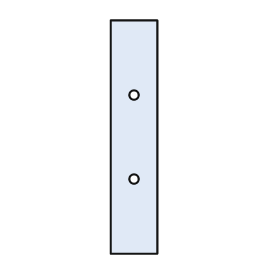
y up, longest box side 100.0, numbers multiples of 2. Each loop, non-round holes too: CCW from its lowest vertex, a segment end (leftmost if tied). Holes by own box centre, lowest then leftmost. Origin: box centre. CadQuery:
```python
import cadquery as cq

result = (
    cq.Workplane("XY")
    .moveTo(-10.0, -50.0)
    .lineTo(10.0, -50.0)
    .lineTo(10.0, 50.0)
    .lineTo(-10.0, 50.0)
    .close()
    .moveTo(0.0, -18.0)
    .circle(2.0)
    .moveTo(0.0, 18.0)
    .circle(2.0)
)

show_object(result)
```